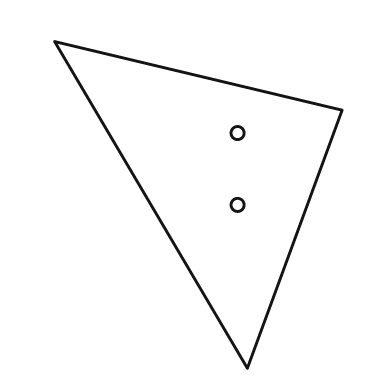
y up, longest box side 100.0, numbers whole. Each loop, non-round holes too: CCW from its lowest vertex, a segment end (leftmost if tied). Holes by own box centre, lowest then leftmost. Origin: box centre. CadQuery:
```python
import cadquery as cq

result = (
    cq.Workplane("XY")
    .moveTo(15.0, -50.0)
    .lineTo(44.0, 29.0)
    .lineTo(-44.0, 50.0)
    .close()
    .moveTo(12.0, 0.0)
    .circle(2.0)
    .moveTo(12.0, 22.0)
    .circle(2.0)
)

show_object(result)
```